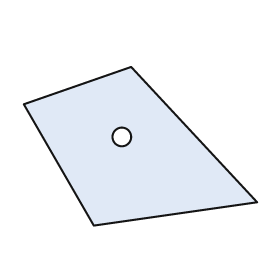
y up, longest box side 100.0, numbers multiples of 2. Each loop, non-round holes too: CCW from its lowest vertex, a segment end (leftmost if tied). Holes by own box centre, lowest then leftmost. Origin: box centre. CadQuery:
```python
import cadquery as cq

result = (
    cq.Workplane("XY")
    .moveTo(-20.0, -34.0)
    .lineTo(50.0, -24.0)
    .lineTo(-4.0, 34.0)
    .lineTo(-50.0, 18.0)
    .close()
    .moveTo(-8.0, 4.0)
    .circle(4.0)
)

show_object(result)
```